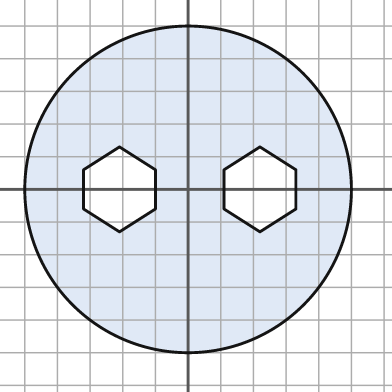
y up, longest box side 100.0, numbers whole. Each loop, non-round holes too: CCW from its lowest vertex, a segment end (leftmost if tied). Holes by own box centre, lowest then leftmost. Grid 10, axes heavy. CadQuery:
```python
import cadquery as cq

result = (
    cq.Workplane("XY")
    .moveTo(0.0, 0.0)
    .circle(50.0)
    .moveTo(-21.0, -13.0)
    .lineTo(-10.0, -6.0)
    .lineTo(-10.0, 6.0)
    .lineTo(-21.0, 13.0)
    .lineTo(-32.0, 6.0)
    .lineTo(-32.0, -6.0)
    .close()
    .moveTo(22.0, -13.0)
    .lineTo(33.0, -6.0)
    .lineTo(33.0, 6.0)
    .lineTo(22.0, 13.0)
    .lineTo(11.0, 6.0)
    .lineTo(11.0, -6.0)
    .close()
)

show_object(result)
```